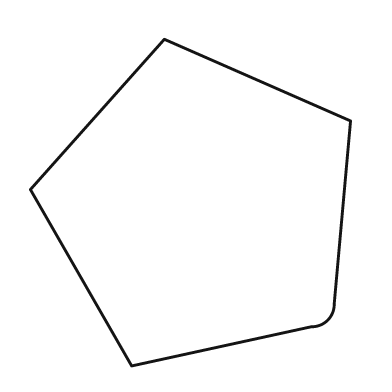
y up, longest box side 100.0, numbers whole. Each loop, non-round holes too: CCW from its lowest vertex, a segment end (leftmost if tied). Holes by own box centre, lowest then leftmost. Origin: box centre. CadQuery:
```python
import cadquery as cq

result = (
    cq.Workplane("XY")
    .moveTo(-18.0, -50.0)
    .lineTo(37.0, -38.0)
    .threePointArc((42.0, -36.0), (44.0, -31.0))
    .lineTo(49.0, 25.0)
    .lineTo(-8.0, 50.0)
    .lineTo(-49.0, 4.0)
    .close()
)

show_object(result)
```